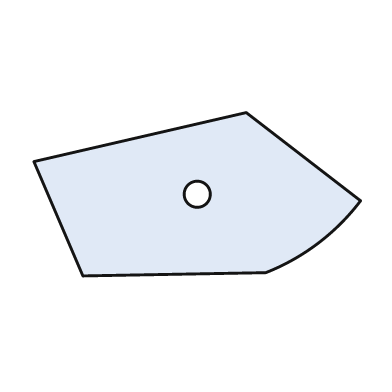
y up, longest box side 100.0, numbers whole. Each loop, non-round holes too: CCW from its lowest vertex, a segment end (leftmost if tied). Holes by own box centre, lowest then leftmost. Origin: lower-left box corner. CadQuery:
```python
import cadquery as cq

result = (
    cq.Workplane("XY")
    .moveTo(15.0, 0.0)
    .lineTo(71.0, 1.0)
    .threePointArc((87.0, 10.0), (100.0, 23.0))
    .lineTo(65.0, 50.0)
    .lineTo(0.0, 35.0)
    .close()
    .moveTo(50.0, 25.0)
    .circle(4.0)
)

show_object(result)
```